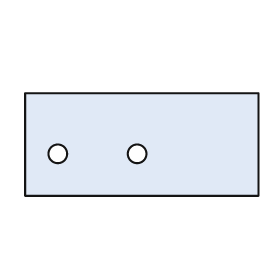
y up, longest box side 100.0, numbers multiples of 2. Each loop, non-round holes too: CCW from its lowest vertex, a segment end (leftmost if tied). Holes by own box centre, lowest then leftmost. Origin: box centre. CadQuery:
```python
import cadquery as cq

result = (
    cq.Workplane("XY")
    .moveTo(-50.0, -22.0)
    .lineTo(50.0, -22.0)
    .lineTo(50.0, 22.0)
    .lineTo(-50.0, 22.0)
    .close()
    .moveTo(-36.0, -4.0)
    .circle(4.0)
    .moveTo(-2.0, -4.0)
    .circle(4.0)
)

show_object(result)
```